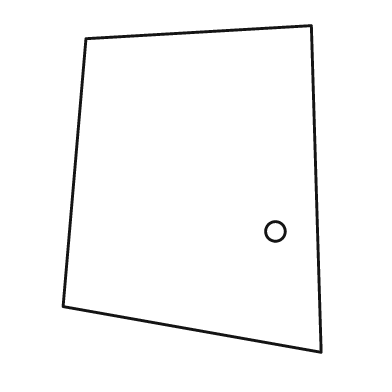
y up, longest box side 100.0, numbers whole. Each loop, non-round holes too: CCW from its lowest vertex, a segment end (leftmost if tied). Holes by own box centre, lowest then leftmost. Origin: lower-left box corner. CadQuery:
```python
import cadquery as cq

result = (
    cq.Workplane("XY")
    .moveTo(79.0, 0.0)
    .lineTo(76.0, 100.0)
    .lineTo(7.0, 96.0)
    .lineTo(0.0, 14.0)
    .close()
    .moveTo(65.0, 37.0)
    .circle(3.0)
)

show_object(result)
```